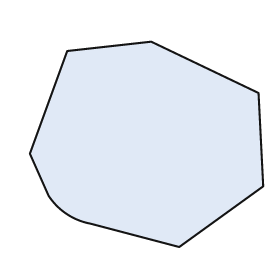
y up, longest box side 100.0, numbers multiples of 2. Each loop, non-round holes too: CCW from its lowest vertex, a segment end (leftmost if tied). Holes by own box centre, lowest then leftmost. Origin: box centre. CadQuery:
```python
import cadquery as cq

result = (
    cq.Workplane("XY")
    .moveTo(14.0, -44.0)
    .lineTo(50.0, -18.0)
    .lineTo(48.0, 22.0)
    .lineTo(2.0, 44.0)
    .lineTo(-34.0, 40.0)
    .lineTo(-50.0, -4.0)
    .lineTo(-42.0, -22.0)
    .threePointArc((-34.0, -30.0), (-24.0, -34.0))
    .close()
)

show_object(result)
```